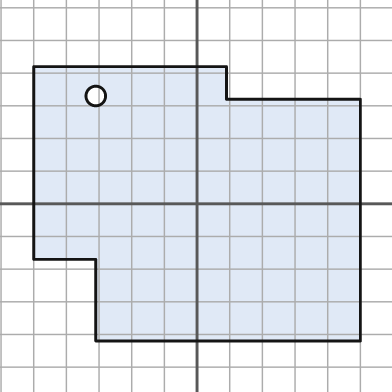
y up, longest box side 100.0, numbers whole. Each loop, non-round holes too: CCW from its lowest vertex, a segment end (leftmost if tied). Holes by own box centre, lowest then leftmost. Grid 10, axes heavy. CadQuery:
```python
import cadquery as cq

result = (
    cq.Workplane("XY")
    .moveTo(-31.0, -42.0)
    .lineTo(50.0, -42.0)
    .lineTo(50.0, 32.0)
    .lineTo(9.0, 32.0)
    .lineTo(9.0, 42.0)
    .lineTo(-50.0, 42.0)
    .lineTo(-50.0, -17.0)
    .lineTo(-31.0, -17.0)
    .close()
    .moveTo(-31.0, 33.0)
    .circle(3.0)
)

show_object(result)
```